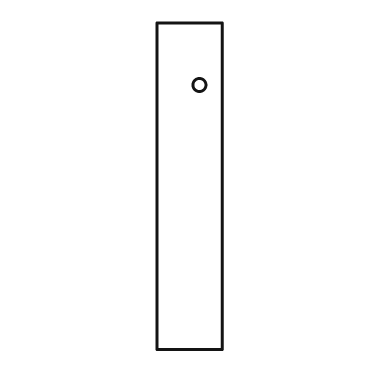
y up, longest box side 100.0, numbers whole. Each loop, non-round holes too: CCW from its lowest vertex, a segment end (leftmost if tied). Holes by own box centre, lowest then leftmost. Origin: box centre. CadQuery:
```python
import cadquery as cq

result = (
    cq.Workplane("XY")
    .moveTo(-10.0, -50.0)
    .lineTo(10.0, -50.0)
    .lineTo(10.0, 50.0)
    .lineTo(-10.0, 50.0)
    .close()
    .moveTo(3.0, 31.0)
    .circle(2.0)
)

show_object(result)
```